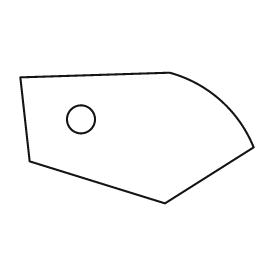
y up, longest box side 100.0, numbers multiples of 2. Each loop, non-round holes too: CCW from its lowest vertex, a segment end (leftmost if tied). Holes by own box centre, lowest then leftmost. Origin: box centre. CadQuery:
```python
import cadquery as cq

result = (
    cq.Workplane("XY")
    .moveTo(12.0, -28.0)
    .lineTo(50.0, -4.0)
    .threePointArc((36.0, 16.0), (14.0, 28.0))
    .lineTo(-50.0, 26.0)
    .lineTo(-46.0, -10.0)
    .close()
    .moveTo(-24.0, 8.0)
    .circle(6.0)
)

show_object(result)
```